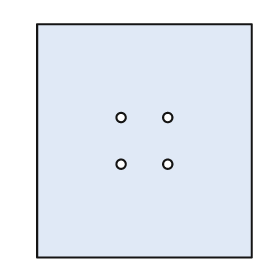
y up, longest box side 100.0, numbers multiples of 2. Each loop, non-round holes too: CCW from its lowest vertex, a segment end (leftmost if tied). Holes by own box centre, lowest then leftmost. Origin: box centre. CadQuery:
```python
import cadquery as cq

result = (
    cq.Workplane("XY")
    .moveTo(-46.0, -50.0)
    .lineTo(46.0, -50.0)
    .lineTo(46.0, 50.0)
    .lineTo(-46.0, 50.0)
    .close()
    .moveTo(-10.0, -10.0)
    .circle(2.0)
    .moveTo(10.0, -10.0)
    .circle(2.0)
    .moveTo(-10.0, 10.0)
    .circle(2.0)
    .moveTo(10.0, 10.0)
    .circle(2.0)
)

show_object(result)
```